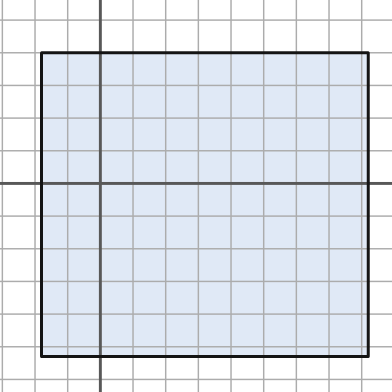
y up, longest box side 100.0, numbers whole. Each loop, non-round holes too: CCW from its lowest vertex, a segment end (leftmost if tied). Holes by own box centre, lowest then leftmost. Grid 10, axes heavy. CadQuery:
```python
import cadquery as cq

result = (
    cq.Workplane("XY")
    .moveTo(-18.0, -53.0)
    .lineTo(82.0, -53.0)
    .lineTo(82.0, 40.0)
    .lineTo(-18.0, 40.0)
    .close()
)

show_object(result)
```